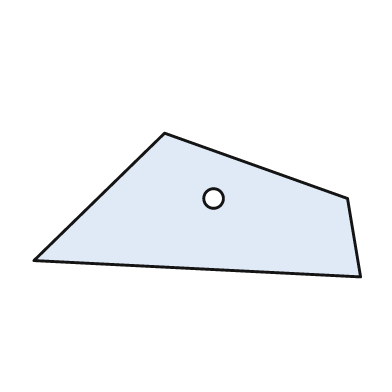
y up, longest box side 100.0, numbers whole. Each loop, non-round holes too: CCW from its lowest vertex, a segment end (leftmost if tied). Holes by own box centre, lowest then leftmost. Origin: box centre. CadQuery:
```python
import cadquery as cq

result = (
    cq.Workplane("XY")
    .moveTo(50.0, -22.0)
    .lineTo(46.0, 2.0)
    .lineTo(-10.0, 22.0)
    .lineTo(-50.0, -17.0)
    .close()
    .moveTo(5.0, 2.0)
    .circle(3.0)
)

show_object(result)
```